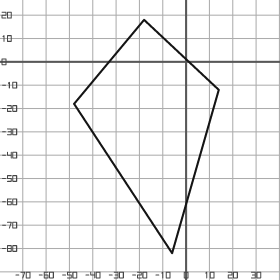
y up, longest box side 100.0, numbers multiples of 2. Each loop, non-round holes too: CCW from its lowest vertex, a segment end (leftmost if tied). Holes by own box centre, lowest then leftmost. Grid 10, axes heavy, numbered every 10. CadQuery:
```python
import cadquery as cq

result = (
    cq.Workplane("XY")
    .moveTo(-6.0, -82.0)
    .lineTo(14.0, -12.0)
    .lineTo(-18.0, 18.0)
    .lineTo(-48.0, -18.0)
    .close()
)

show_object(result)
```